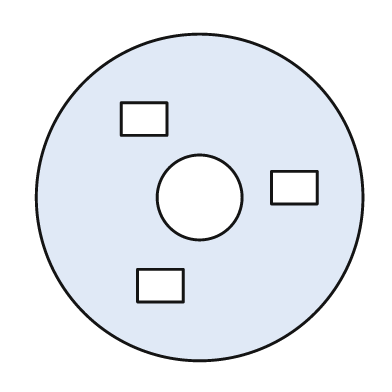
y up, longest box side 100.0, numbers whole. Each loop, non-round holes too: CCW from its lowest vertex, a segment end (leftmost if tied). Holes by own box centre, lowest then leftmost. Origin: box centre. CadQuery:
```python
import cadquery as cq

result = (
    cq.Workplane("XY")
    .moveTo(0.0, 0.0)
    .circle(50.0)
    .moveTo(-19.0, -32.0)
    .lineTo(-5.0, -32.0)
    .lineTo(-5.0, -22.0)
    .lineTo(-19.0, -22.0)
    .close()
    .moveTo(0.0, 0.0)
    .circle(13.0)
    .moveTo(22.0, -2.0)
    .lineTo(36.0, -2.0)
    .lineTo(36.0, 8.0)
    .lineTo(22.0, 8.0)
    .close()
    .moveTo(-24.0, 19.0)
    .lineTo(-10.0, 19.0)
    .lineTo(-10.0, 29.0)
    .lineTo(-24.0, 29.0)
    .close()
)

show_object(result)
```